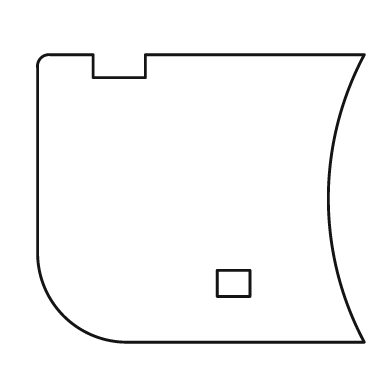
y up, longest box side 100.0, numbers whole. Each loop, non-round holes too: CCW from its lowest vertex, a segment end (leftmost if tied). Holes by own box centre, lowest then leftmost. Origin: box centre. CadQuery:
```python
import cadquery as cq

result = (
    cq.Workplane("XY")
    .moveTo(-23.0, -44.0)
    .lineTo(50.0, -44.0)
    .threePointArc((39.0, 0.0), (50.0, 44.0))
    .lineTo(-17.0, 44.0)
    .lineTo(-17.0, 37.0)
    .lineTo(-33.0, 37.0)
    .lineTo(-33.0, 44.0)
    .lineTo(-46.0, 44.0)
    .threePointArc((-49.0, 43.0), (-50.0, 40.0))
    .lineTo(-50.0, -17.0)
    .threePointArc((-42.0, -36.0), (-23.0, -44.0))
    .close()
    .moveTo(5.0, -30.0)
    .lineTo(15.0, -30.0)
    .lineTo(15.0, -22.0)
    .lineTo(5.0, -22.0)
    .close()
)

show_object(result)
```